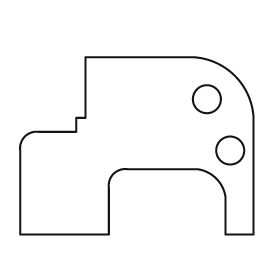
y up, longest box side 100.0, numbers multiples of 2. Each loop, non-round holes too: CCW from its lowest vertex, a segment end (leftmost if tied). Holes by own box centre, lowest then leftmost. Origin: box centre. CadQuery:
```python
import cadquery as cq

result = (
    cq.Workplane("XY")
    .moveTo(-50.0, -38.0)
    .lineTo(-12.0, -38.0)
    .lineTo(-12.0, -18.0)
    .threePointArc((-10.0, -12.0), (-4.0, -10.0))
    .lineTo(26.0, -10.0)
    .threePointArc((34.0, -14.0), (38.0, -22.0))
    .lineTo(38.0, -38.0)
    .lineTo(50.0, -38.0)
    .lineTo(50.0, 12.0)
    .threePointArc((42.0, 30.0), (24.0, 38.0))
    .lineTo(-22.0, 38.0)
    .lineTo(-22.0, 12.0)
    .lineTo(-26.0, 12.0)
    .lineTo(-26.0, 6.0)
    .lineTo(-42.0, 6.0)
    .threePointArc((-48.0, 4.0), (-50.0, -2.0))
    .close()
    .moveTo(40.0, -2.0)
    .circle(6.0)
    .moveTo(30.0, 20.0)
    .circle(6.0)
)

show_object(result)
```